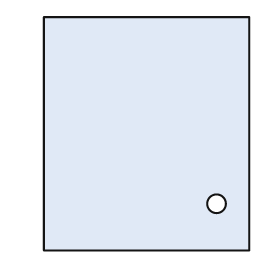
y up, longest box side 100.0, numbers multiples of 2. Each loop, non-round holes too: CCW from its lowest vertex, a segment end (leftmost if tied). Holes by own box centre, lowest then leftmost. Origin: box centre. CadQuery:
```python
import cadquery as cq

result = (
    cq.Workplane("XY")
    .moveTo(-44.0, -50.0)
    .lineTo(44.0, -50.0)
    .lineTo(44.0, 50.0)
    .lineTo(-44.0, 50.0)
    .close()
    .moveTo(30.0, -30.0)
    .circle(4.0)
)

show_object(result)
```